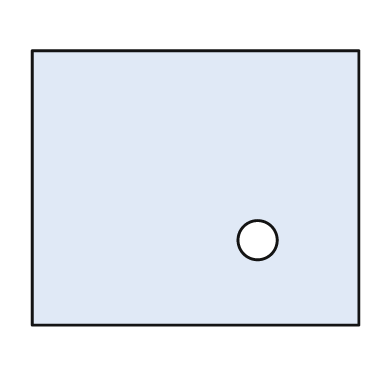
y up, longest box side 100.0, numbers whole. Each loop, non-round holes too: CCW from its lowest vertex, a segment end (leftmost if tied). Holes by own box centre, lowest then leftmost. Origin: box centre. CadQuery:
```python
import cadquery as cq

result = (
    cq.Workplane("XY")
    .moveTo(-50.0, -42.0)
    .lineTo(50.0, -42.0)
    .lineTo(50.0, 42.0)
    .lineTo(-50.0, 42.0)
    .close()
    .moveTo(19.0, -16.0)
    .circle(6.0)
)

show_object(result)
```